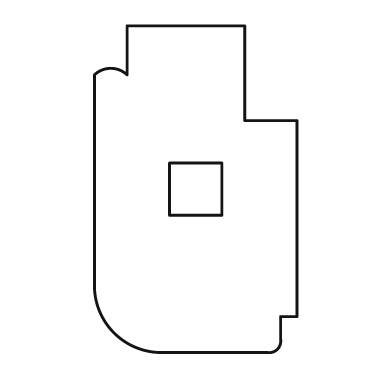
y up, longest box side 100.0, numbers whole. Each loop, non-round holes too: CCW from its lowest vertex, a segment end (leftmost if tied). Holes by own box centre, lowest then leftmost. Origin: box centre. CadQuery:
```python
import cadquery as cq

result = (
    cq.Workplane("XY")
    .moveTo(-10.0, -50.0)
    .lineTo(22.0, -50.0)
    .threePointArc((25.0, -49.0), (26.0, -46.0))
    .lineTo(26.0, -39.0)
    .lineTo(31.0, -39.0)
    .lineTo(31.0, 21.0)
    .lineTo(15.0, 21.0)
    .lineTo(15.0, 50.0)
    .lineTo(-21.0, 50.0)
    .lineTo(-21.0, 35.0)
    .threePointArc((-26.0, 37.0), (-31.0, 35.0))
    .lineTo(-31.0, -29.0)
    .threePointArc((-25.0, -44.0), (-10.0, -50.0))
    .close()
    .moveTo(-8.0, -8.0)
    .lineTo(8.0, -8.0)
    .lineTo(8.0, 8.0)
    .lineTo(-8.0, 8.0)
    .close()
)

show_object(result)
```